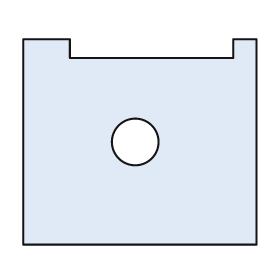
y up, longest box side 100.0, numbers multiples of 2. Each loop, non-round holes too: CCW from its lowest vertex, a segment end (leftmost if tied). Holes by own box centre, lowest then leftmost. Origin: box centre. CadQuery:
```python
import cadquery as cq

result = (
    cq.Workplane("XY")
    .moveTo(-50.0, -44.0)
    .lineTo(50.0, -44.0)
    .lineTo(50.0, 44.0)
    .lineTo(40.0, 44.0)
    .lineTo(40.0, 36.0)
    .lineTo(-30.0, 36.0)
    .lineTo(-30.0, 44.0)
    .lineTo(-50.0, 44.0)
    .close()
    .moveTo(-2.0, 0.0)
    .circle(10.0)
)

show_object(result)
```